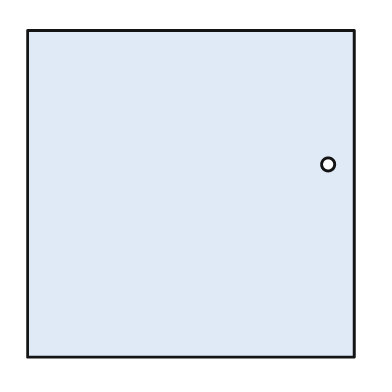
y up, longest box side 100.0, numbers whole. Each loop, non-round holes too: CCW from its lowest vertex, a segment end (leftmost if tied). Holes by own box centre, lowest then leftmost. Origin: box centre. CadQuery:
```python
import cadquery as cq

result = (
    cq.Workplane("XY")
    .moveTo(-50.0, -50.0)
    .lineTo(50.0, -50.0)
    .lineTo(50.0, 50.0)
    .lineTo(-50.0, 50.0)
    .close()
    .moveTo(42.0, 9.0)
    .circle(2.0)
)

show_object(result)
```